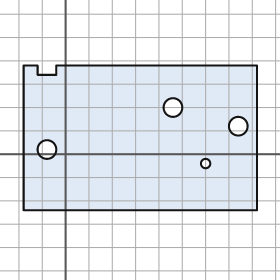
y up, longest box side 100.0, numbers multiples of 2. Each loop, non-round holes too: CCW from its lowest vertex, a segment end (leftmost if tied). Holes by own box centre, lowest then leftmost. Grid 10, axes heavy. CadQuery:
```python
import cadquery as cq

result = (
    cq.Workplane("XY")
    .moveTo(-18.0, -24.0)
    .lineTo(82.0, -24.0)
    .lineTo(82.0, 38.0)
    .lineTo(-4.0, 38.0)
    .lineTo(-4.0, 34.0)
    .lineTo(-12.0, 34.0)
    .lineTo(-12.0, 38.0)
    .lineTo(-18.0, 38.0)
    .close()
    .moveTo(60.0, -4.0)
    .circle(2.0)
    .moveTo(-8.0, 2.0)
    .circle(4.0)
    .moveTo(74.0, 12.0)
    .circle(4.0)
    .moveTo(46.0, 20.0)
    .circle(4.0)
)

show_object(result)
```